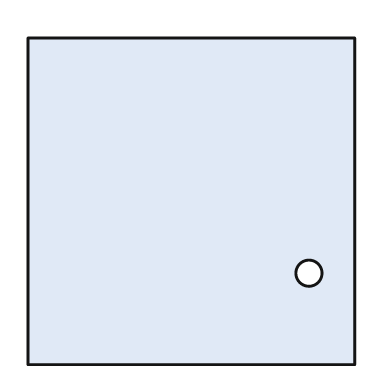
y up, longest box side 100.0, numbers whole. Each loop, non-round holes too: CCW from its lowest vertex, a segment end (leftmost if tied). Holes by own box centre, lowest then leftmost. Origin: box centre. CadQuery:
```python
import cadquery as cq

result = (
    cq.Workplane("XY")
    .moveTo(-50.0, -50.0)
    .lineTo(50.0, -50.0)
    .lineTo(50.0, 50.0)
    .lineTo(-50.0, 50.0)
    .close()
    .moveTo(36.0, -22.0)
    .circle(4.0)
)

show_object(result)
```